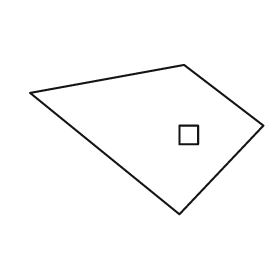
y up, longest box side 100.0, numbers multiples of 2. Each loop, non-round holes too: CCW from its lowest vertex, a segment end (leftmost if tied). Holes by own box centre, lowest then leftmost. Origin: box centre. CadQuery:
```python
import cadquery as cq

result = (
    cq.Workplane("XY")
    .moveTo(14.0, -32.0)
    .lineTo(50.0, 6.0)
    .lineTo(16.0, 32.0)
    .lineTo(-50.0, 20.0)
    .close()
    .moveTo(14.0, -2.0)
    .lineTo(22.0, -2.0)
    .lineTo(22.0, 6.0)
    .lineTo(14.0, 6.0)
    .close()
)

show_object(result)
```